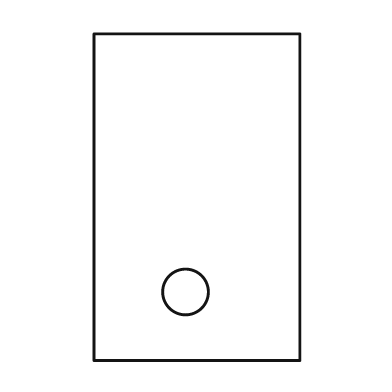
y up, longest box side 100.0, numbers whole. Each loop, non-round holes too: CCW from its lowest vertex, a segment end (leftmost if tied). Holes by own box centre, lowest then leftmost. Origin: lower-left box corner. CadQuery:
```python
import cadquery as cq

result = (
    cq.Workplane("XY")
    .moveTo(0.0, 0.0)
    .lineTo(63.0, 0.0)
    .lineTo(63.0, 100.0)
    .lineTo(0.0, 100.0)
    .close()
    .moveTo(28.0, 21.0)
    .circle(7.0)
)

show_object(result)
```